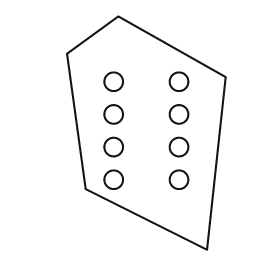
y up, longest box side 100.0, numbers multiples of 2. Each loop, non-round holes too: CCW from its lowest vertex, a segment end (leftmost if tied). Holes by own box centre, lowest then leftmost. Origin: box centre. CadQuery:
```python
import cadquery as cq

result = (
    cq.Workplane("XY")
    .moveTo(26.0, -50.0)
    .lineTo(34.0, 24.0)
    .lineTo(-12.0, 50.0)
    .lineTo(-34.0, 34.0)
    .lineTo(-26.0, -24.0)
    .close()
    .moveTo(-14.0, -20.0)
    .circle(4.0)
    .moveTo(14.0, -20.0)
    .circle(4.0)
    .moveTo(-14.0, -6.0)
    .circle(4.0)
    .moveTo(14.0, -6.0)
    .circle(4.0)
    .moveTo(-14.0, 8.0)
    .circle(4.0)
    .moveTo(14.0, 8.0)
    .circle(4.0)
    .moveTo(-14.0, 22.0)
    .circle(4.0)
    .moveTo(14.0, 22.0)
    .circle(4.0)
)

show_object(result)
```